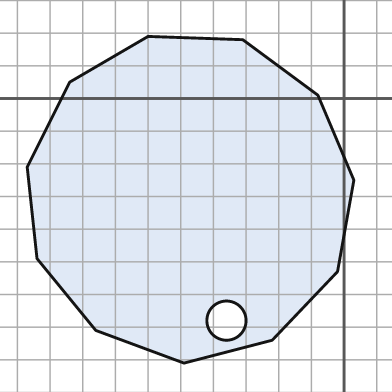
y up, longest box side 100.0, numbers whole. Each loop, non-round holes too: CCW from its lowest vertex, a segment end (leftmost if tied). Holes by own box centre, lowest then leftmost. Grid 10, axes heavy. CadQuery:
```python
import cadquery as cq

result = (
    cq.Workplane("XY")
    .moveTo(-49.0, -81.0)
    .lineTo(-22.0, -74.0)
    .lineTo(-2.0, -53.0)
    .lineTo(3.0, -25.0)
    .lineTo(-8.0, 1.0)
    .lineTo(-31.0, 18.0)
    .lineTo(-60.0, 19.0)
    .lineTo(-84.0, 5.0)
    .lineTo(-97.0, -21.0)
    .lineTo(-94.0, -49.0)
    .lineTo(-76.0, -71.0)
    .close()
    .moveTo(-36.0, -68.0)
    .circle(6.0)
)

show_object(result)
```